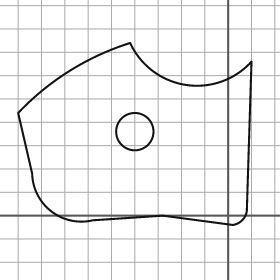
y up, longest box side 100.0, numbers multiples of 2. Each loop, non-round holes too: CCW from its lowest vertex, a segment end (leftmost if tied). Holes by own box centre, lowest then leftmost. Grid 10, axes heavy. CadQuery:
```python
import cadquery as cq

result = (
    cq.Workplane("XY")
    .moveTo(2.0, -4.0)
    .threePointArc((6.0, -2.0), (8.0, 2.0))
    .lineTo(10.0, 66.0)
    .threePointArc((-18.0, 56.0), (-42.0, 74.0))
    .threePointArc((-68.0, 62.0), (-90.0, 44.0))
    .lineTo(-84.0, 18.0)
    .threePointArc((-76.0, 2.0), (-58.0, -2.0))
    .lineTo(-28.0, 0.0)
    .close()
    .moveTo(-40.0, 36.0)
    .circle(8.0)
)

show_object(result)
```